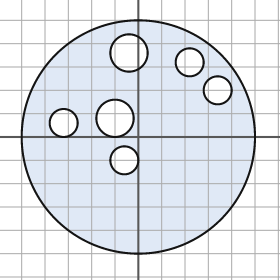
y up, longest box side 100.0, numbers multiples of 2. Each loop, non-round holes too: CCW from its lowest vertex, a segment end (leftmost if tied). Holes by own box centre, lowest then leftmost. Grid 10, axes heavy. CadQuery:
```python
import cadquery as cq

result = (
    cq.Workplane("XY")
    .moveTo(0.0, 0.0)
    .circle(50.0)
    .moveTo(-6.0, -10.0)
    .circle(6.0)
    .moveTo(-32.0, 6.0)
    .circle(6.0)
    .moveTo(-10.0, 8.0)
    .circle(8.0)
    .moveTo(34.0, 20.0)
    .circle(6.0)
    .moveTo(22.0, 32.0)
    .circle(6.0)
    .moveTo(-4.0, 36.0)
    .circle(8.0)
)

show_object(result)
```